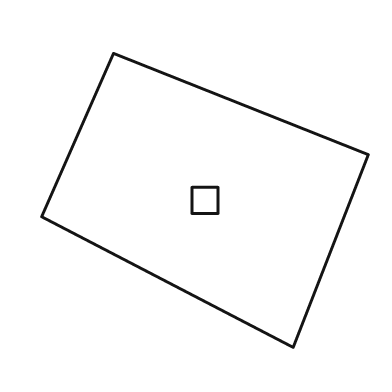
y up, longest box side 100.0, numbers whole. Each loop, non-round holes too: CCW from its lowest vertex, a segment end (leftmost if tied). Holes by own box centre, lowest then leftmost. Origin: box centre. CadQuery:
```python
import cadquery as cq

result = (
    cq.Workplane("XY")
    .moveTo(27.0, -45.0)
    .lineTo(50.0, 14.0)
    .lineTo(-28.0, 45.0)
    .lineTo(-50.0, -5.0)
    .close()
    .moveTo(-4.0, -4.0)
    .lineTo(4.0, -4.0)
    .lineTo(4.0, 4.0)
    .lineTo(-4.0, 4.0)
    .close()
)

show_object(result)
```